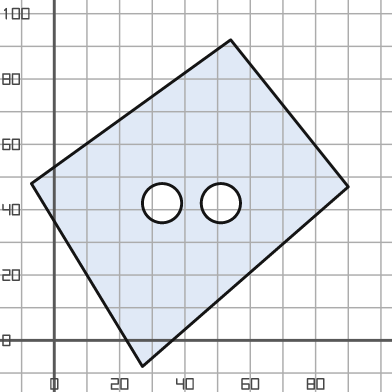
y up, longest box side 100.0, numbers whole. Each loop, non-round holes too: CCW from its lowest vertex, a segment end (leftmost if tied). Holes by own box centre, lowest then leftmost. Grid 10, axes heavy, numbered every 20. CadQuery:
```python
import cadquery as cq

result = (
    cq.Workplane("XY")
    .moveTo(27.0, -8.0)
    .lineTo(90.0, 47.0)
    .lineTo(54.0, 92.0)
    .lineTo(-7.0, 48.0)
    .close()
    .moveTo(33.0, 42.0)
    .circle(6.0)
    .moveTo(51.0, 42.0)
    .circle(6.0)
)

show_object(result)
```